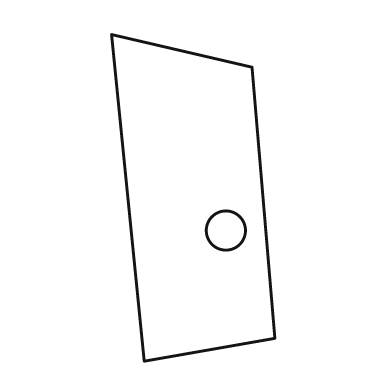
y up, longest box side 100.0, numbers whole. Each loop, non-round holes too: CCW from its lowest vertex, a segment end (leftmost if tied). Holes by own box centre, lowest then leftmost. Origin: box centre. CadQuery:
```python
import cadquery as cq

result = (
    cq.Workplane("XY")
    .moveTo(-15.0, -50.0)
    .lineTo(25.0, -43.0)
    .lineTo(18.0, 40.0)
    .lineTo(-25.0, 50.0)
    .close()
    .moveTo(10.0, -10.0)
    .circle(6.0)
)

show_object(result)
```